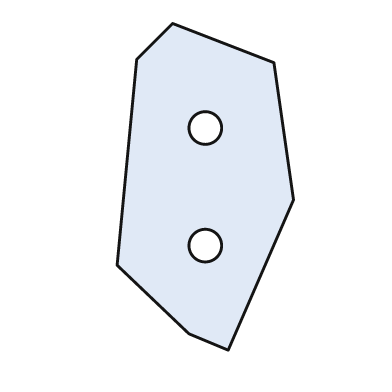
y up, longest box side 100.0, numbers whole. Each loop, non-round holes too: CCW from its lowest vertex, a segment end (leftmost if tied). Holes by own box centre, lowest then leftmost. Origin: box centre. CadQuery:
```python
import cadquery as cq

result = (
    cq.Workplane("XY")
    .moveTo(7.0, -50.0)
    .lineTo(27.0, -4.0)
    .lineTo(21.0, 38.0)
    .lineTo(-10.0, 50.0)
    .lineTo(-21.0, 39.0)
    .lineTo(-27.0, -24.0)
    .lineTo(-5.0, -45.0)
    .close()
    .moveTo(0.0, -18.0)
    .circle(5.0)
    .moveTo(0.0, 18.0)
    .circle(5.0)
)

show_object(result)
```